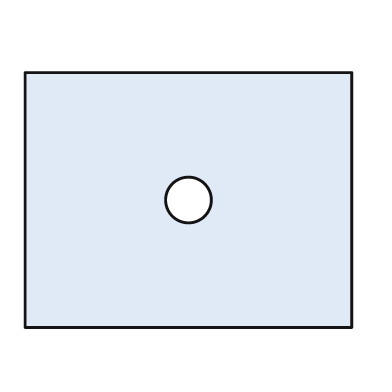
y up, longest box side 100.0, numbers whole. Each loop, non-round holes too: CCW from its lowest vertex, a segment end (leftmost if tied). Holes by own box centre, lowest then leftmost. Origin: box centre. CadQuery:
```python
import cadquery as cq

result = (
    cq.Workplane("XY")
    .moveTo(-50.0, -39.0)
    .lineTo(50.0, -39.0)
    .lineTo(50.0, 39.0)
    .lineTo(-50.0, 39.0)
    .close()
    .moveTo(0.0, 0.0)
    .circle(7.0)
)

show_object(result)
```